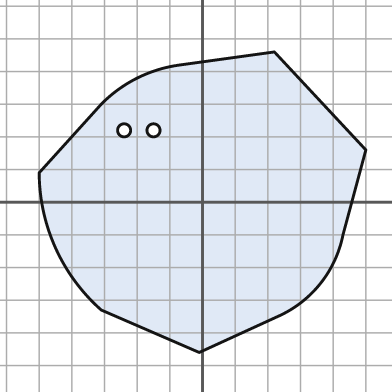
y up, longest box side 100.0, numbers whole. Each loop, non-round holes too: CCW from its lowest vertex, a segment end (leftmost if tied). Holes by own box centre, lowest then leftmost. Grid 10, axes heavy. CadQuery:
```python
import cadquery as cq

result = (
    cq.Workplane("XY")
    .moveTo(-1.0, -46.0)
    .lineTo(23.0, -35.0)
    .threePointArc((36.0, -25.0), (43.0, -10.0))
    .lineTo(50.0, 16.0)
    .lineTo(22.0, 46.0)
    .lineTo(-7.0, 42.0)
    .threePointArc((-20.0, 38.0), (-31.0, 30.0))
    .lineTo(-50.0, 9.0)
    .threePointArc((-45.0, -14.0), (-31.0, -33.0))
    .close()
    .moveTo(-24.0, 22.0)
    .circle(2.0)
    .moveTo(-15.0, 22.0)
    .circle(2.0)
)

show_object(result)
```